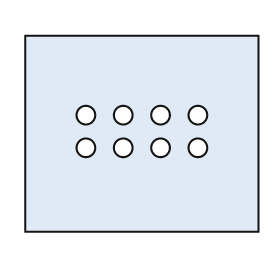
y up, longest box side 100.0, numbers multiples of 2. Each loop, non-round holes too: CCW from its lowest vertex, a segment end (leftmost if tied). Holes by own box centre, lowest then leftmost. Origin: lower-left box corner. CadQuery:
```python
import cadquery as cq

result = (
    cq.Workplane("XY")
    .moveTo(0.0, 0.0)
    .lineTo(100.0, 0.0)
    .lineTo(100.0, 84.0)
    .lineTo(0.0, 84.0)
    .close()
    .moveTo(26.0, 36.0)
    .circle(4.0)
    .moveTo(42.0, 36.0)
    .circle(4.0)
    .moveTo(58.0, 36.0)
    .circle(4.0)
    .moveTo(74.0, 36.0)
    .circle(4.0)
    .moveTo(26.0, 50.0)
    .circle(4.0)
    .moveTo(42.0, 50.0)
    .circle(4.0)
    .moveTo(58.0, 50.0)
    .circle(4.0)
    .moveTo(74.0, 50.0)
    .circle(4.0)
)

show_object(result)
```